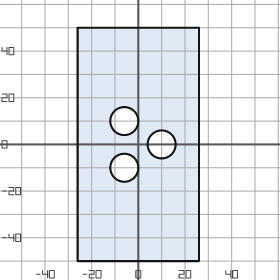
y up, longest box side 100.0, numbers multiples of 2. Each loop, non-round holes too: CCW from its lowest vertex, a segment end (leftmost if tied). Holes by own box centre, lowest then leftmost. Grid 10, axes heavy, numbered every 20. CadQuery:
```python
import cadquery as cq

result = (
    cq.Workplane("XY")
    .moveTo(-26.0, -50.0)
    .lineTo(26.0, -50.0)
    .lineTo(26.0, 50.0)
    .lineTo(-26.0, 50.0)
    .close()
    .moveTo(-6.0, -10.0)
    .circle(6.0)
    .moveTo(10.0, 0.0)
    .circle(6.0)
    .moveTo(-6.0, 10.0)
    .circle(6.0)
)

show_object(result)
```